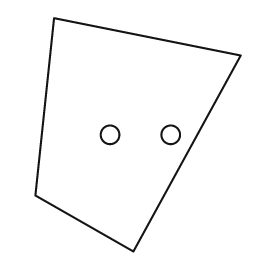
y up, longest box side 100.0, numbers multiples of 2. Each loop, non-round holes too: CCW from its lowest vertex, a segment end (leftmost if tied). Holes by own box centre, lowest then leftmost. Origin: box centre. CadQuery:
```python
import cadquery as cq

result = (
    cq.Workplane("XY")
    .moveTo(-2.0, -50.0)
    .lineTo(44.0, 34.0)
    .lineTo(-36.0, 50.0)
    .lineTo(-44.0, -26.0)
    .close()
    .moveTo(-12.0, 0.0)
    .circle(4.0)
    .moveTo(14.0, 0.0)
    .circle(4.0)
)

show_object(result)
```